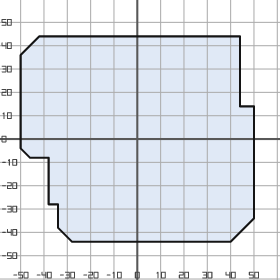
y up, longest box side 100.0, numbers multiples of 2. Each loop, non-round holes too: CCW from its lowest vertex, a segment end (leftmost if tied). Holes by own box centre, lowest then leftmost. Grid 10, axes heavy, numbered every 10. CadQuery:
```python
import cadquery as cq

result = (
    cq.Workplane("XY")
    .moveTo(-28.0, -44.0)
    .lineTo(40.0, -44.0)
    .lineTo(50.0, -34.0)
    .lineTo(50.0, 14.0)
    .lineTo(44.0, 14.0)
    .lineTo(44.0, 44.0)
    .lineTo(-42.0, 44.0)
    .lineTo(-50.0, 36.0)
    .lineTo(-50.0, -4.0)
    .lineTo(-46.0, -8.0)
    .lineTo(-38.0, -8.0)
    .lineTo(-38.0, -28.0)
    .lineTo(-34.0, -28.0)
    .lineTo(-34.0, -38.0)
    .close()
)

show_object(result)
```